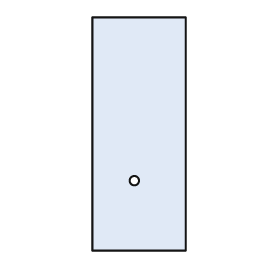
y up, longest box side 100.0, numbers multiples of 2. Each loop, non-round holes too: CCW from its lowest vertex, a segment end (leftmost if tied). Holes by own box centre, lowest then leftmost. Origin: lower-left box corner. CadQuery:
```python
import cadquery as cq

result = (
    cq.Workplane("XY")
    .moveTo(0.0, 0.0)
    .lineTo(40.0, 0.0)
    .lineTo(40.0, 100.0)
    .lineTo(0.0, 100.0)
    .close()
    .moveTo(18.0, 30.0)
    .circle(2.0)
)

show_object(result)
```